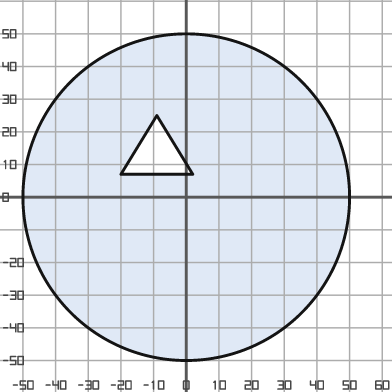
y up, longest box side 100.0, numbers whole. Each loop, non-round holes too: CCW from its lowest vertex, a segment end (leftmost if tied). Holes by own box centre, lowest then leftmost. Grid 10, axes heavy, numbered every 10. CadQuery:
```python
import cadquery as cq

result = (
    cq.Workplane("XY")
    .moveTo(0.0, 0.0)
    .circle(50.0)
    .moveTo(-20.0, 7.0)
    .lineTo(2.0, 7.0)
    .lineTo(-9.0, 25.0)
    .close()
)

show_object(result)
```